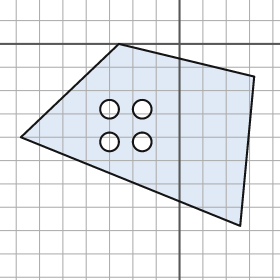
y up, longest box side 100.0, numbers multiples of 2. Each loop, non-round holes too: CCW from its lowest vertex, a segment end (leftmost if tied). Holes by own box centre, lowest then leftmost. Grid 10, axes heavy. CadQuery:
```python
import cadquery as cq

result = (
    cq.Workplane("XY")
    .moveTo(26.0, -78.0)
    .lineTo(32.0, -14.0)
    .lineTo(-26.0, 0.0)
    .lineTo(-68.0, -40.0)
    .close()
    .moveTo(-30.0, -42.0)
    .circle(4.0)
    .moveTo(-16.0, -42.0)
    .circle(4.0)
    .moveTo(-30.0, -28.0)
    .circle(4.0)
    .moveTo(-16.0, -28.0)
    .circle(4.0)
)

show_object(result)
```